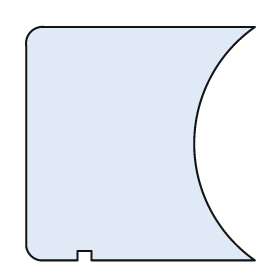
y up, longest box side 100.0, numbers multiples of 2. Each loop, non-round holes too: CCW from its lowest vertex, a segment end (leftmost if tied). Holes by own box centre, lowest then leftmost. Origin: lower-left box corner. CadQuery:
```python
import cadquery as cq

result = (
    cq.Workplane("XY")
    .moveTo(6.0, 0.0)
    .lineTo(22.0, 0.0)
    .lineTo(22.0, 4.0)
    .lineTo(28.0, 4.0)
    .lineTo(28.0, 0.0)
    .lineTo(98.0, 0.0)
    .threePointArc((72.0, 50.0), (98.0, 100.0))
    .lineTo(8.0, 100.0)
    .threePointArc((2.0, 98.0), (0.0, 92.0))
    .lineTo(0.0, 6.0)
    .threePointArc((2.0, 2.0), (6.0, 0.0))
    .close()
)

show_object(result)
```